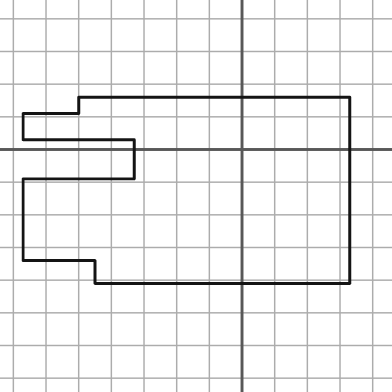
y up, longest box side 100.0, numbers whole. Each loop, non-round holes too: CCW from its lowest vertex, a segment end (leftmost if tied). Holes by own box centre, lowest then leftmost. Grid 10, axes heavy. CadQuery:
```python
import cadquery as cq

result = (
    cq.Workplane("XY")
    .moveTo(-45.0, -41.0)
    .lineTo(33.0, -41.0)
    .lineTo(33.0, 16.0)
    .lineTo(-50.0, 16.0)
    .lineTo(-50.0, 11.0)
    .lineTo(-67.0, 11.0)
    .lineTo(-67.0, 3.0)
    .lineTo(-33.0, 3.0)
    .lineTo(-33.0, -9.0)
    .lineTo(-67.0, -9.0)
    .lineTo(-67.0, -34.0)
    .lineTo(-45.0, -34.0)
    .close()
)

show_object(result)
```